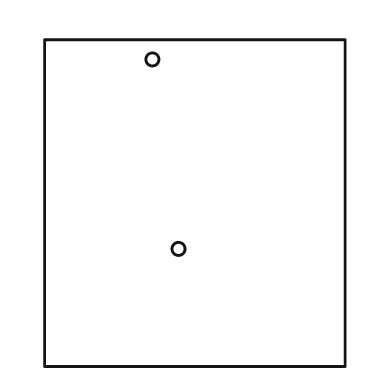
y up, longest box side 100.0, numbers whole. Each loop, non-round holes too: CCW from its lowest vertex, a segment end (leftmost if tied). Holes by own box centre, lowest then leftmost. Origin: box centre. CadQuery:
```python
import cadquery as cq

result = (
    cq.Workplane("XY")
    .moveTo(-46.0, -50.0)
    .lineTo(46.0, -50.0)
    .lineTo(46.0, 50.0)
    .lineTo(-46.0, 50.0)
    .close()
    .moveTo(-5.0, -14.0)
    .circle(2.0)
    .moveTo(-13.0, 44.0)
    .circle(2.0)
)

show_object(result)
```